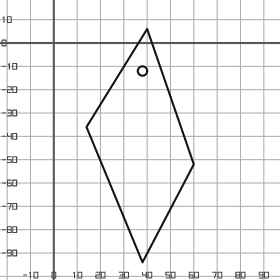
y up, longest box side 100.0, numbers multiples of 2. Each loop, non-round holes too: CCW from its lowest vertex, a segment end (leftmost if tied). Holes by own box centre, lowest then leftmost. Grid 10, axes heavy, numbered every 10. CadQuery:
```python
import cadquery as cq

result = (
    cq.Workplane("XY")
    .moveTo(38.0, -94.0)
    .lineTo(60.0, -52.0)
    .lineTo(40.0, 6.0)
    .lineTo(14.0, -36.0)
    .close()
    .moveTo(38.0, -12.0)
    .circle(2.0)
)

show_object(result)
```